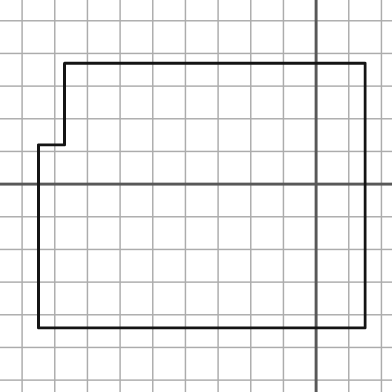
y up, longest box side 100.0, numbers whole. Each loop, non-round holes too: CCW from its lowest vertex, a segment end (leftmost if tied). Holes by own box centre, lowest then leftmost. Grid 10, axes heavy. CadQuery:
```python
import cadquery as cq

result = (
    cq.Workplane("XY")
    .moveTo(-85.0, -44.0)
    .lineTo(15.0, -44.0)
    .lineTo(15.0, 37.0)
    .lineTo(-77.0, 37.0)
    .lineTo(-77.0, 12.0)
    .lineTo(-85.0, 12.0)
    .close()
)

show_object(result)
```